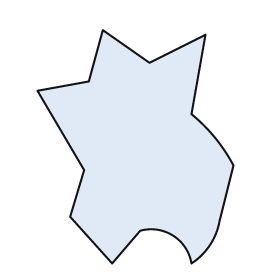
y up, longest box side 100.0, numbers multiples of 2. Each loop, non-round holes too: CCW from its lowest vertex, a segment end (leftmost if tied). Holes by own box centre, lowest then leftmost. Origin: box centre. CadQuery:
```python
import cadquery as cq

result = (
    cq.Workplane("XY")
    .moveTo(-10.0, -50.0)
    .lineTo(2.0, -36.0)
    .threePointArc((16.0, -38.0), (24.0, -50.0))
    .threePointArc((32.0, -42.0), (36.0, -32.0))
    .lineTo(42.0, -8.0)
    .threePointArc((34.0, 4.0), (24.0, 14.0))
    .lineTo(30.0, 48.0)
    .lineTo(6.0, 36.0)
    .lineTo(-14.0, 50.0)
    .lineTo(-20.0, 28.0)
    .lineTo(-42.0, 24.0)
    .lineTo(-22.0, -10.0)
    .lineTo(-28.0, -30.0)
    .close()
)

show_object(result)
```